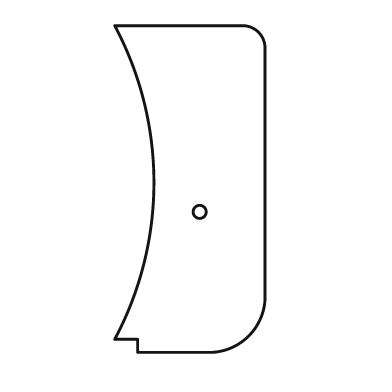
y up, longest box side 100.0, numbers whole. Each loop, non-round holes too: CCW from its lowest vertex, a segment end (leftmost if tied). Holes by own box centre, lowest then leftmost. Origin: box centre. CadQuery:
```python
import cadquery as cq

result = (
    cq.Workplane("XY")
    .moveTo(-16.0, -50.0)
    .lineTo(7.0, -50.0)
    .threePointArc((18.0, -45.0), (23.0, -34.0))
    .lineTo(23.0, 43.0)
    .threePointArc((21.0, 48.0), (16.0, 50.0))
    .lineTo(-23.0, 50.0)
    .threePointArc((-11.0, 2.0), (-23.0, -46.0))
    .lineTo(-16.0, -46.0)
    .close()
    .moveTo(3.0, -7.0)
    .circle(2.0)
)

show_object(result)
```